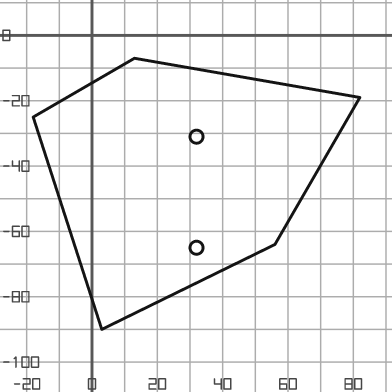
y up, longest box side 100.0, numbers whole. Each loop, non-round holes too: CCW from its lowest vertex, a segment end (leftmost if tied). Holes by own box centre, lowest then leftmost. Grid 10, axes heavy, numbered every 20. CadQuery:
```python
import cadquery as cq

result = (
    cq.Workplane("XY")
    .moveTo(3.0, -90.0)
    .lineTo(56.0, -64.0)
    .lineTo(82.0, -19.0)
    .lineTo(13.0, -7.0)
    .lineTo(-18.0, -25.0)
    .close()
    .moveTo(32.0, -65.0)
    .circle(2.0)
    .moveTo(32.0, -31.0)
    .circle(2.0)
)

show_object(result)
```